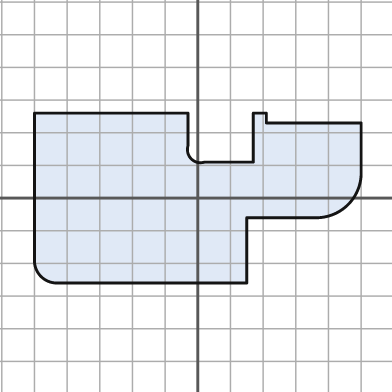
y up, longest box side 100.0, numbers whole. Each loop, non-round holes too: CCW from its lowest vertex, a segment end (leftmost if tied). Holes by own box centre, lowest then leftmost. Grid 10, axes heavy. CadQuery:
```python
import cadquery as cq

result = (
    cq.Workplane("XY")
    .moveTo(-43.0, -26.0)
    .lineTo(15.0, -26.0)
    .lineTo(15.0, -6.0)
    .lineTo(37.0, -6.0)
    .threePointArc((46.0, -2.0), (50.0, 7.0))
    .lineTo(50.0, 23.0)
    .lineTo(21.0, 23.0)
    .lineTo(21.0, 26.0)
    .lineTo(17.0, 26.0)
    .lineTo(17.0, 11.0)
    .lineTo(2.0, 11.0)
    .threePointArc((-2.0, 12.0), (-3.0, 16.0))
    .lineTo(-3.0, 26.0)
    .lineTo(-50.0, 26.0)
    .lineTo(-50.0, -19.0)
    .threePointArc((-48.0, -24.0), (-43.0, -26.0))
    .close()
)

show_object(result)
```